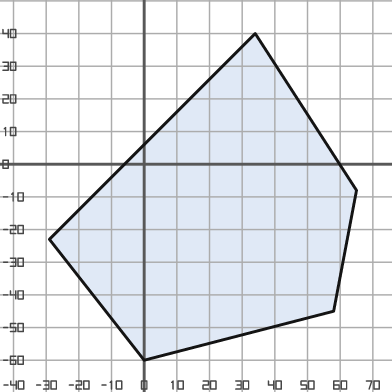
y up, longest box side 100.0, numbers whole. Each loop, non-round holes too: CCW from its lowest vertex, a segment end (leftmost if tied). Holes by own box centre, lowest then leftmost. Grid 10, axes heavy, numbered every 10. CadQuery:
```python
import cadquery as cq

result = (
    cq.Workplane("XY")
    .moveTo(0.0, -60.0)
    .lineTo(58.0, -45.0)
    .lineTo(65.0, -8.0)
    .lineTo(34.0, 40.0)
    .lineTo(-29.0, -23.0)
    .close()
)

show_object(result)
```